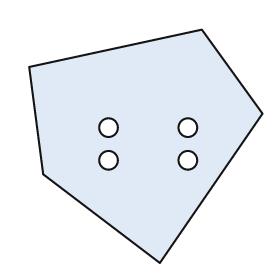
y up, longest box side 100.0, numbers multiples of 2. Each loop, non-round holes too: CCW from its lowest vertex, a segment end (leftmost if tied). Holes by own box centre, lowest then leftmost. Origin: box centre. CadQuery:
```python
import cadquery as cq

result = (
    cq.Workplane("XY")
    .moveTo(6.0, -50.0)
    .lineTo(50.0, 14.0)
    .lineTo(24.0, 50.0)
    .lineTo(-50.0, 34.0)
    .lineTo(-44.0, -12.0)
    .close()
    .moveTo(-16.0, -6.0)
    .circle(4.0)
    .moveTo(18.0, -6.0)
    .circle(4.0)
    .moveTo(-16.0, 8.0)
    .circle(4.0)
    .moveTo(18.0, 8.0)
    .circle(4.0)
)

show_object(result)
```